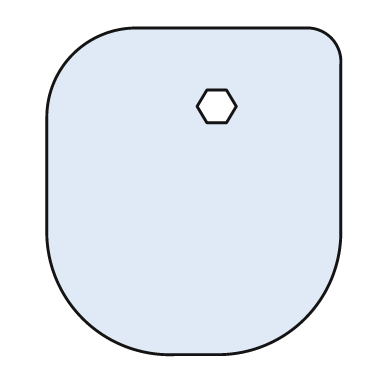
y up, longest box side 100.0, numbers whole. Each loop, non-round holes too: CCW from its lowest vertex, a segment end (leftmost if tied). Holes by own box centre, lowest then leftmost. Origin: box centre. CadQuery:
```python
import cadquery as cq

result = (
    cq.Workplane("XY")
    .moveTo(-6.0, -50.0)
    .lineTo(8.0, -50.0)
    .threePointArc((34.0, -39.0), (45.0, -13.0))
    .lineTo(45.0, 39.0)
    .threePointArc((42.0, 47.0), (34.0, 50.0))
    .lineTo(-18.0, 50.0)
    .threePointArc((-37.0, 42.0), (-45.0, 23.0))
    .lineTo(-45.0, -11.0)
    .threePointArc((-34.0, -39.0), (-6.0, -50.0))
    .close()
    .moveTo(4.0, 21.0)
    .lineTo(10.0, 21.0)
    .lineTo(13.0, 26.0)
    .lineTo(10.0, 31.0)
    .lineTo(4.0, 31.0)
    .lineTo(1.0, 26.0)
    .close()
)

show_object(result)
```